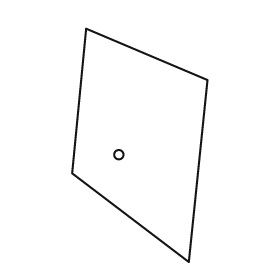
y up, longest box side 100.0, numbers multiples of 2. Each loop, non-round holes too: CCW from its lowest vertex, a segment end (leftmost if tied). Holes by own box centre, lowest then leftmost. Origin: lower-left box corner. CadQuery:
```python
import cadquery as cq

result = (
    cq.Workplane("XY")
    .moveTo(50.0, 0.0)
    .lineTo(58.0, 78.0)
    .lineTo(6.0, 100.0)
    .lineTo(0.0, 38.0)
    .close()
    .moveTo(20.0, 46.0)
    .circle(2.0)
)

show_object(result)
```